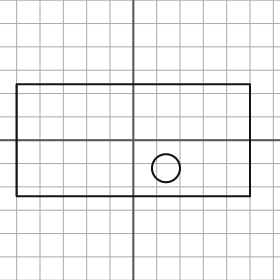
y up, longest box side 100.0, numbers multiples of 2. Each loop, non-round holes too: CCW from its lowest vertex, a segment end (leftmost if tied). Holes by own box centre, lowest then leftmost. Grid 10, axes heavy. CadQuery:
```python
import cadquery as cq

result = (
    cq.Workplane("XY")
    .moveTo(-50.0, -24.0)
    .lineTo(50.0, -24.0)
    .lineTo(50.0, 24.0)
    .lineTo(-50.0, 24.0)
    .close()
    .moveTo(14.0, -12.0)
    .circle(6.0)
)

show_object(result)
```